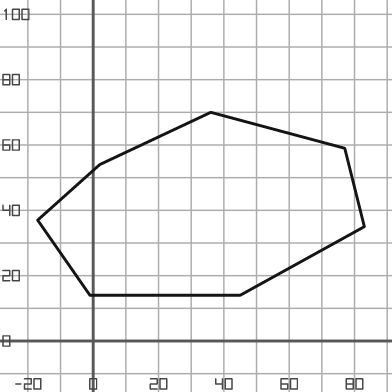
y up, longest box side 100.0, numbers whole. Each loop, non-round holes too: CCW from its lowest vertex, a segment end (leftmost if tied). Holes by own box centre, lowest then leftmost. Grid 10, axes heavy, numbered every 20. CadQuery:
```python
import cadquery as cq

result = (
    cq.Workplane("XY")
    .moveTo(-1.0, 14.0)
    .lineTo(45.0, 14.0)
    .lineTo(83.0, 35.0)
    .lineTo(77.0, 59.0)
    .lineTo(36.0, 70.0)
    .lineTo(2.0, 54.0)
    .lineTo(-17.0, 37.0)
    .close()
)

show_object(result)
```